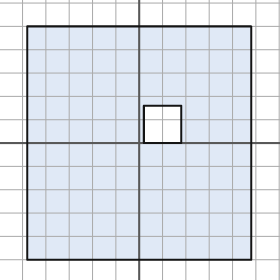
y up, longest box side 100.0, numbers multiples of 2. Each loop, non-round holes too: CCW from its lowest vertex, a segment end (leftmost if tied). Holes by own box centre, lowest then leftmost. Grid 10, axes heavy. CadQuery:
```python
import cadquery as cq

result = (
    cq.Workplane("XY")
    .moveTo(-48.0, -50.0)
    .lineTo(48.0, -50.0)
    .lineTo(48.0, 50.0)
    .lineTo(-48.0, 50.0)
    .close()
    .moveTo(2.0, 0.0)
    .lineTo(18.0, 0.0)
    .lineTo(18.0, 16.0)
    .lineTo(2.0, 16.0)
    .close()
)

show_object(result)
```